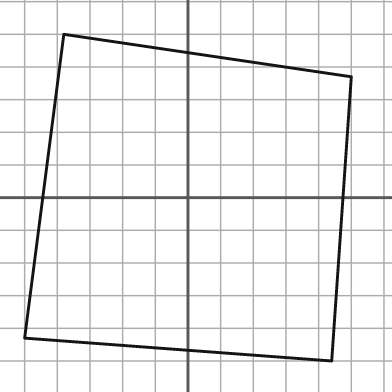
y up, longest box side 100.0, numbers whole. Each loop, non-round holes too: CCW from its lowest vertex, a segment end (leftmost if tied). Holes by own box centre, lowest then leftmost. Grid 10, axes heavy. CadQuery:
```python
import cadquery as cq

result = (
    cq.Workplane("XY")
    .moveTo(44.0, -50.0)
    .lineTo(50.0, 37.0)
    .lineTo(-38.0, 50.0)
    .lineTo(-50.0, -43.0)
    .close()
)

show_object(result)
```